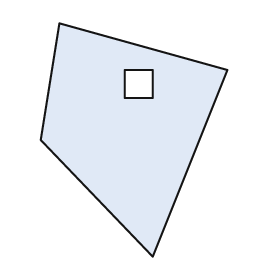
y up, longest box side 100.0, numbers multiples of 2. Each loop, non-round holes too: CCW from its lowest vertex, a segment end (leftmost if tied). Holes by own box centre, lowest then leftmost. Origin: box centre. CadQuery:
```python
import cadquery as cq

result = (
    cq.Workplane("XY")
    .moveTo(8.0, -50.0)
    .lineTo(40.0, 30.0)
    .lineTo(-32.0, 50.0)
    .lineTo(-40.0, 0.0)
    .close()
    .moveTo(-4.0, 18.0)
    .lineTo(8.0, 18.0)
    .lineTo(8.0, 30.0)
    .lineTo(-4.0, 30.0)
    .close()
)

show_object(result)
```